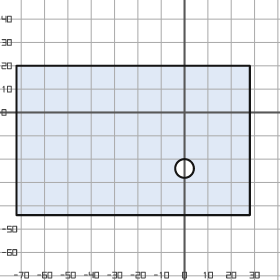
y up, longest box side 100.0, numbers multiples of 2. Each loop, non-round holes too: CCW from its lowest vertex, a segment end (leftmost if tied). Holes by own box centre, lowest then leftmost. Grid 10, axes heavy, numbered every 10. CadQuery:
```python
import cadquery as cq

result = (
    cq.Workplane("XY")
    .moveTo(-72.0, -44.0)
    .lineTo(28.0, -44.0)
    .lineTo(28.0, 20.0)
    .lineTo(-72.0, 20.0)
    .close()
    .moveTo(0.0, -24.0)
    .circle(4.0)
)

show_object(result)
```